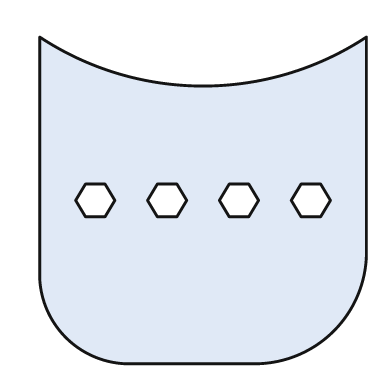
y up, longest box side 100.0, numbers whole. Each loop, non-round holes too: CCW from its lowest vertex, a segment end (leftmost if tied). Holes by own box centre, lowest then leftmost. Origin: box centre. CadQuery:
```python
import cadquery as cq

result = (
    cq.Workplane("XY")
    .moveTo(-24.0, -50.0)
    .lineTo(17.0, -50.0)
    .threePointArc((40.0, -40.0), (50.0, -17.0))
    .lineTo(50.0, 50.0)
    .threePointArc((0.0, 35.0), (-50.0, 50.0))
    .lineTo(-50.0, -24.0)
    .threePointArc((-42.0, -42.0), (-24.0, -50.0))
    .close()
    .moveTo(-36.0, -5.0)
    .lineTo(-30.0, -5.0)
    .lineTo(-27.0, 0.0)
    .lineTo(-30.0, 5.0)
    .lineTo(-36.0, 5.0)
    .lineTo(-39.0, 0.0)
    .close()
    .moveTo(-14.0, -5.0)
    .lineTo(-8.0, -5.0)
    .lineTo(-5.0, 0.0)
    .lineTo(-8.0, 5.0)
    .lineTo(-14.0, 5.0)
    .lineTo(-17.0, 0.0)
    .close()
    .moveTo(8.0, -5.0)
    .lineTo(14.0, -5.0)
    .lineTo(17.0, 0.0)
    .lineTo(14.0, 5.0)
    .lineTo(8.0, 5.0)
    .lineTo(5.0, 0.0)
    .close()
    .moveTo(30.0, -5.0)
    .lineTo(36.0, -5.0)
    .lineTo(39.0, 0.0)
    .lineTo(36.0, 5.0)
    .lineTo(30.0, 5.0)
    .lineTo(27.0, 0.0)
    .close()
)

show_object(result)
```